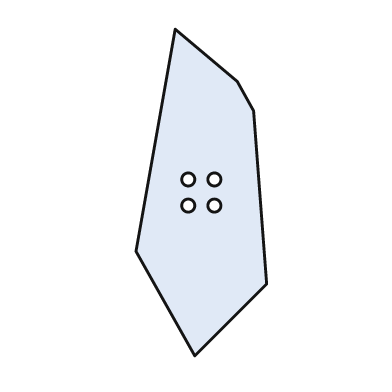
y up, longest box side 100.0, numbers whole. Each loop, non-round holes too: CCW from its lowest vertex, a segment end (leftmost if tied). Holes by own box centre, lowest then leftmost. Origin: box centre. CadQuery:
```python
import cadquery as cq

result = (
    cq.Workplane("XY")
    .moveTo(-2.0, -50.0)
    .lineTo(20.0, -28.0)
    .lineTo(16.0, 25.0)
    .lineTo(11.0, 34.0)
    .lineTo(-8.0, 50.0)
    .lineTo(-20.0, -18.0)
    .close()
    .moveTo(-4.0, -4.0)
    .circle(2.0)
    .moveTo(4.0, -4.0)
    .circle(2.0)
    .moveTo(-4.0, 4.0)
    .circle(2.0)
    .moveTo(4.0, 4.0)
    .circle(2.0)
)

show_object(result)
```